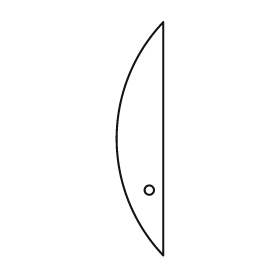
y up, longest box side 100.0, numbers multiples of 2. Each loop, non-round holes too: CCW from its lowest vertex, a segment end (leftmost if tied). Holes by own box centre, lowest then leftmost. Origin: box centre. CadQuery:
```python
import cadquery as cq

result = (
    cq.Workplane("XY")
    .moveTo(10.0, -50.0)
    .lineTo(10.0, 50.0)
    .threePointArc((-10.0, 0.0), (10.0, -50.0))
    .close()
    .moveTo(4.0, -22.0)
    .circle(2.0)
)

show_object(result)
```